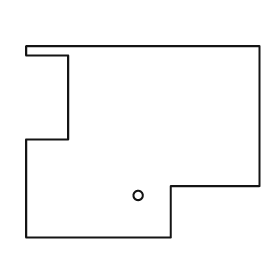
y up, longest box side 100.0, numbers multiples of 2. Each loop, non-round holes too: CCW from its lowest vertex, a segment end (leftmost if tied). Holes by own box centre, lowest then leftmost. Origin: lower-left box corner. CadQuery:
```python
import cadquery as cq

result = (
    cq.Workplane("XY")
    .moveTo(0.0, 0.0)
    .lineTo(62.0, 0.0)
    .lineTo(62.0, 22.0)
    .lineTo(100.0, 22.0)
    .lineTo(100.0, 82.0)
    .lineTo(0.0, 82.0)
    .lineTo(0.0, 78.0)
    .lineTo(18.0, 78.0)
    .lineTo(18.0, 42.0)
    .lineTo(0.0, 42.0)
    .close()
    .moveTo(48.0, 18.0)
    .circle(2.0)
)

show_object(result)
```